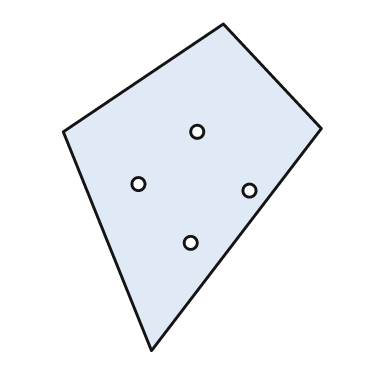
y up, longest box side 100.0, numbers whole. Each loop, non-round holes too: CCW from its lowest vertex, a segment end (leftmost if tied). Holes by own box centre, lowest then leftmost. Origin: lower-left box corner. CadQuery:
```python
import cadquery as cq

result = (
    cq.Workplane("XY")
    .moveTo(27.0, 0.0)
    .lineTo(79.0, 68.0)
    .lineTo(49.0, 100.0)
    .lineTo(0.0, 67.0)
    .close()
    .moveTo(39.0, 33.0)
    .circle(2.0)
    .moveTo(57.0, 49.0)
    .circle(2.0)
    .moveTo(23.0, 51.0)
    .circle(2.0)
    .moveTo(41.0, 67.0)
    .circle(2.0)
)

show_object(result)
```